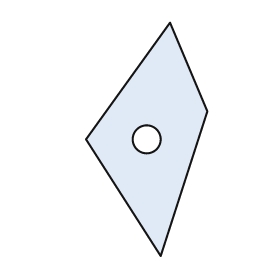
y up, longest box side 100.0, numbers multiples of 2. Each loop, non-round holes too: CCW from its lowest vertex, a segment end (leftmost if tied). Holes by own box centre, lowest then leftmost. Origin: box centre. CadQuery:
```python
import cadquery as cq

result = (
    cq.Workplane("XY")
    .moveTo(6.0, -50.0)
    .lineTo(26.0, 12.0)
    .lineTo(10.0, 50.0)
    .lineTo(-26.0, 0.0)
    .close()
    .moveTo(0.0, 0.0)
    .circle(6.0)
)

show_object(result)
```